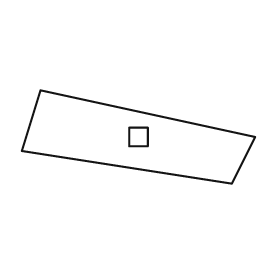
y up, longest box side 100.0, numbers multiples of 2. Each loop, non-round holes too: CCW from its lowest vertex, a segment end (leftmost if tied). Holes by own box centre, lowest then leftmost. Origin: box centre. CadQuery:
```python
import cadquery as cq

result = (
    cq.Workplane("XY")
    .moveTo(40.0, -20.0)
    .lineTo(50.0, 0.0)
    .lineTo(-42.0, 20.0)
    .lineTo(-50.0, -6.0)
    .close()
    .moveTo(-4.0, -4.0)
    .lineTo(4.0, -4.0)
    .lineTo(4.0, 4.0)
    .lineTo(-4.0, 4.0)
    .close()
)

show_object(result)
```